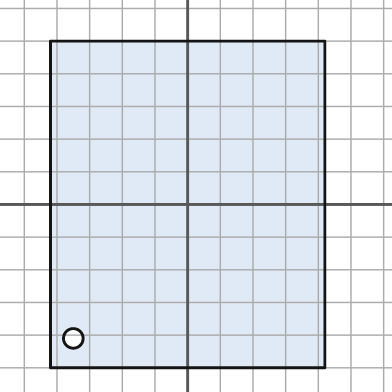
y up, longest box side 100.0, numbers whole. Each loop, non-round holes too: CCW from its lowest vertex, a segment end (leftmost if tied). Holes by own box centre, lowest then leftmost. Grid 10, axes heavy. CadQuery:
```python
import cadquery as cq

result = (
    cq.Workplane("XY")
    .moveTo(-42.0, -50.0)
    .lineTo(42.0, -50.0)
    .lineTo(42.0, 50.0)
    .lineTo(-42.0, 50.0)
    .close()
    .moveTo(-35.0, -41.0)
    .circle(3.0)
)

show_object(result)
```